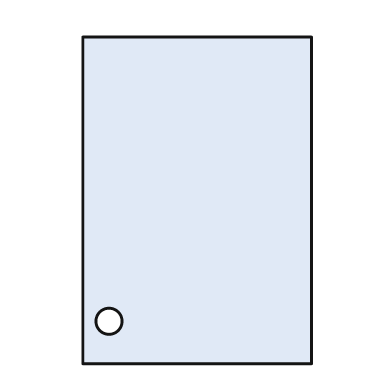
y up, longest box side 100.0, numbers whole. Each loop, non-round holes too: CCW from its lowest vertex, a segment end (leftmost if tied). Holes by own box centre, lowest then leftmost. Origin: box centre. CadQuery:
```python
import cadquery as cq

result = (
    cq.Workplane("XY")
    .moveTo(-35.0, -50.0)
    .lineTo(35.0, -50.0)
    .lineTo(35.0, 50.0)
    .lineTo(-35.0, 50.0)
    .close()
    .moveTo(-27.0, -37.0)
    .circle(4.0)
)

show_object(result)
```